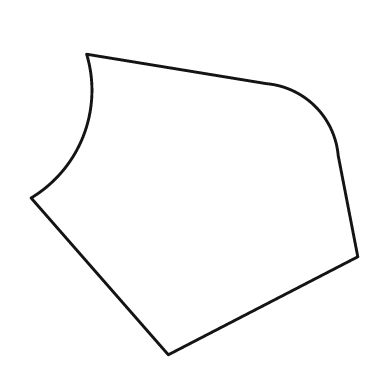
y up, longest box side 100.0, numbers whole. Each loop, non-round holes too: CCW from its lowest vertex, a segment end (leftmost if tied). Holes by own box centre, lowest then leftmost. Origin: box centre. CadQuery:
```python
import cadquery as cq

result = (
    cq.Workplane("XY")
    .moveTo(-8.0, -46.0)
    .lineTo(50.0, -16.0)
    .lineTo(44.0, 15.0)
    .threePointArc((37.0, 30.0), (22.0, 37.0))
    .lineTo(-33.0, 46.0)
    .threePointArc((-34.0, 21.0), (-50.0, 2.0))
    .close()
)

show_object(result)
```